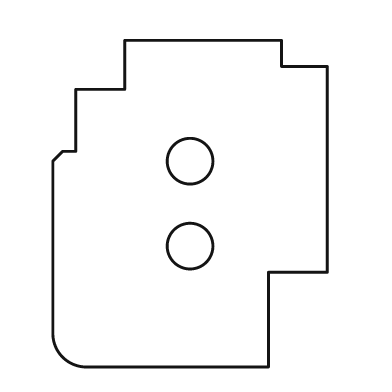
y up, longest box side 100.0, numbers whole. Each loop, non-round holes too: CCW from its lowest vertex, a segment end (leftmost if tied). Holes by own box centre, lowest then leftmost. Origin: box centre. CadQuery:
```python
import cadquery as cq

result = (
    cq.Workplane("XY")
    .moveTo(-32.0, -50.0)
    .lineTo(24.0, -50.0)
    .lineTo(24.0, -21.0)
    .lineTo(42.0, -21.0)
    .lineTo(42.0, 42.0)
    .lineTo(28.0, 42.0)
    .lineTo(28.0, 50.0)
    .lineTo(-20.0, 50.0)
    .lineTo(-20.0, 35.0)
    .lineTo(-35.0, 35.0)
    .lineTo(-35.0, 16.0)
    .lineTo(-39.0, 16.0)
    .lineTo(-42.0, 13.0)
    .lineTo(-42.0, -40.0)
    .threePointArc((-39.0, -47.0), (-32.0, -50.0))
    .close()
    .moveTo(0.0, -13.0)
    .circle(7.0)
    .moveTo(0.0, 13.0)
    .circle(7.0)
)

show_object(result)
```